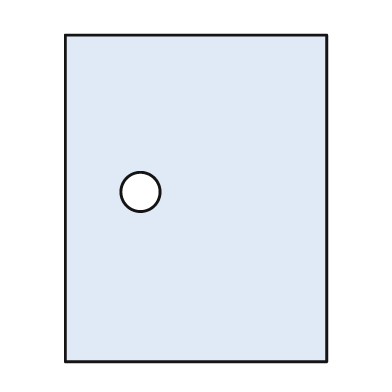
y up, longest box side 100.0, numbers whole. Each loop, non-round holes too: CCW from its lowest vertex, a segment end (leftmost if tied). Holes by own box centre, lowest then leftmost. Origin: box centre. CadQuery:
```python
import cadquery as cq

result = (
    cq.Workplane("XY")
    .moveTo(-40.0, -50.0)
    .lineTo(40.0, -50.0)
    .lineTo(40.0, 50.0)
    .lineTo(-40.0, 50.0)
    .close()
    .moveTo(-17.0, 2.0)
    .circle(6.0)
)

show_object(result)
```